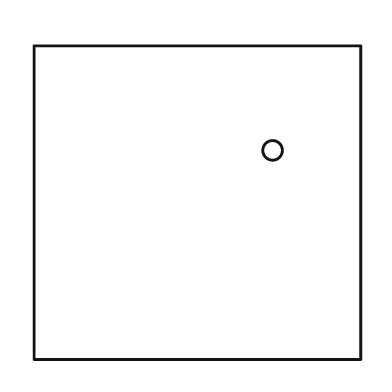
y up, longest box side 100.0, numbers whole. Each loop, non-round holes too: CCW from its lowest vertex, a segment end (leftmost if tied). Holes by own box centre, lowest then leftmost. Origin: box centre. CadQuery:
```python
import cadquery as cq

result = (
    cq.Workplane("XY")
    .moveTo(-50.0, -48.0)
    .lineTo(50.0, -48.0)
    .lineTo(50.0, 48.0)
    .lineTo(-50.0, 48.0)
    .close()
    .moveTo(23.0, 16.0)
    .circle(3.0)
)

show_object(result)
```